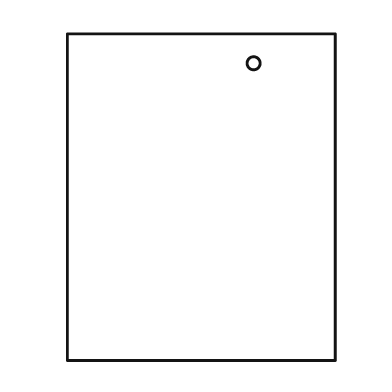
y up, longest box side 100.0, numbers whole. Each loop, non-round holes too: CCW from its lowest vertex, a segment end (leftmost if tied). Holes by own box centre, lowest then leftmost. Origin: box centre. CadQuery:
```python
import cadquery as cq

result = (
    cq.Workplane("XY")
    .moveTo(-41.0, -50.0)
    .lineTo(41.0, -50.0)
    .lineTo(41.0, 50.0)
    .lineTo(-41.0, 50.0)
    .close()
    .moveTo(16.0, 41.0)
    .circle(2.0)
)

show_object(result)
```